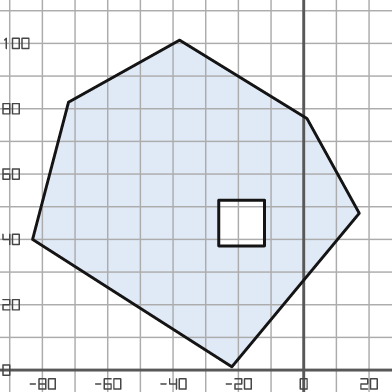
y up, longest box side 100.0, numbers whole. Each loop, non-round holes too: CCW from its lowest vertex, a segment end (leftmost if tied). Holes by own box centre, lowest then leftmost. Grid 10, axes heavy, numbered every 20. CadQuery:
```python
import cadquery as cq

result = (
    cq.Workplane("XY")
    .moveTo(-22.0, 1.0)
    .lineTo(17.0, 48.0)
    .lineTo(1.0, 77.0)
    .lineTo(-38.0, 101.0)
    .lineTo(-72.0, 82.0)
    .lineTo(-83.0, 40.0)
    .close()
    .moveTo(-26.0, 38.0)
    .lineTo(-12.0, 38.0)
    .lineTo(-12.0, 52.0)
    .lineTo(-26.0, 52.0)
    .close()
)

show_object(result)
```